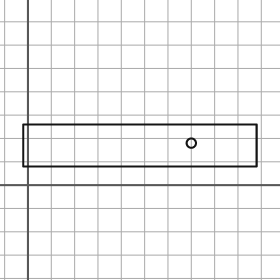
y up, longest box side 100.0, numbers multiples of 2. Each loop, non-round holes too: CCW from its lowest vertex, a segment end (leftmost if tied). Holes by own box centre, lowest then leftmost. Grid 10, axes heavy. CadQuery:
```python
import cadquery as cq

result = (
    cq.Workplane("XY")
    .moveTo(-2.0, 8.0)
    .lineTo(98.0, 8.0)
    .lineTo(98.0, 26.0)
    .lineTo(-2.0, 26.0)
    .close()
    .moveTo(70.0, 18.0)
    .circle(2.0)
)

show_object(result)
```